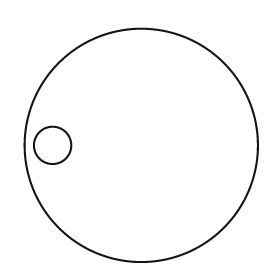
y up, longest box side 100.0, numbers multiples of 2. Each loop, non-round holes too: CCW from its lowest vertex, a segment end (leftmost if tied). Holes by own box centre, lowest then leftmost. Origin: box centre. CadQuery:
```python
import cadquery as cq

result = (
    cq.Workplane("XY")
    .moveTo(0.0, 0.0)
    .circle(50.0)
    .moveTo(-38.0, 0.0)
    .circle(8.0)
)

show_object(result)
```